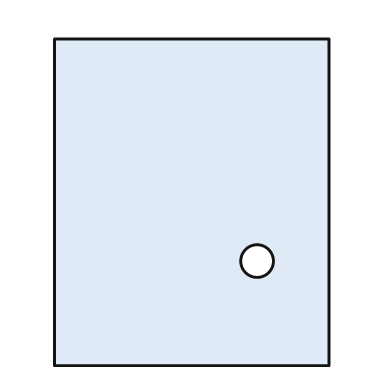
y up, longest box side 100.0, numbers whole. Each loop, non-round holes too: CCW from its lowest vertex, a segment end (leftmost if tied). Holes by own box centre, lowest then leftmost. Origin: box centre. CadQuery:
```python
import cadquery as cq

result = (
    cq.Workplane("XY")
    .moveTo(-42.0, -50.0)
    .lineTo(42.0, -50.0)
    .lineTo(42.0, 50.0)
    .lineTo(-42.0, 50.0)
    .close()
    .moveTo(20.0, -18.0)
    .circle(5.0)
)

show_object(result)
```